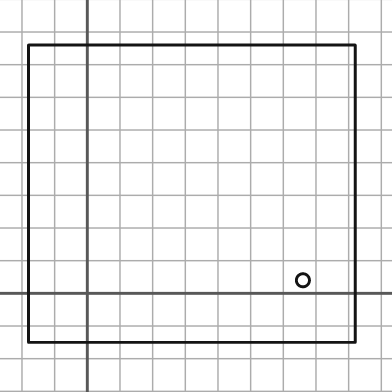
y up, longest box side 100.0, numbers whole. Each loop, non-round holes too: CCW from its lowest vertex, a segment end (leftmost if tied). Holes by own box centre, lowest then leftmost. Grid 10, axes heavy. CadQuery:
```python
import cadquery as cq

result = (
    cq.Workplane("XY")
    .moveTo(-18.0, -15.0)
    .lineTo(82.0, -15.0)
    .lineTo(82.0, 76.0)
    .lineTo(-18.0, 76.0)
    .close()
    .moveTo(66.0, 4.0)
    .circle(2.0)
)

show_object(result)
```